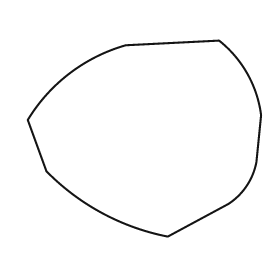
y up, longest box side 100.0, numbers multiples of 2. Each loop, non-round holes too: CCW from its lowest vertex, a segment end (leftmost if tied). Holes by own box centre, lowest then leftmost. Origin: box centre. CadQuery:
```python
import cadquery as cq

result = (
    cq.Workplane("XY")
    .moveTo(10.0, -42.0)
    .lineTo(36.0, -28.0)
    .threePointArc((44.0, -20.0), (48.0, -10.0))
    .lineTo(50.0, 10.0)
    .threePointArc((44.0, 28.0), (32.0, 42.0))
    .lineTo(-8.0, 40.0)
    .threePointArc((-32.0, 28.0), (-50.0, 8.0))
    .lineTo(-42.0, -14.0)
    .threePointArc((-18.0, -32.0), (10.0, -42.0))
    .close()
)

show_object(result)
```